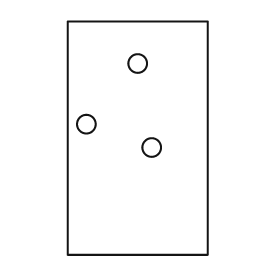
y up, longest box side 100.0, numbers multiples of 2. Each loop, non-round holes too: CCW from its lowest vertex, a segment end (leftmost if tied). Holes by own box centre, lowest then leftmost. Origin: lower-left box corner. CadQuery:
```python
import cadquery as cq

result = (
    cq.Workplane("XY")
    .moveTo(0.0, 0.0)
    .lineTo(60.0, 0.0)
    .lineTo(60.0, 100.0)
    .lineTo(0.0, 100.0)
    .close()
    .moveTo(36.0, 46.0)
    .circle(4.0)
    .moveTo(8.0, 56.0)
    .circle(4.0)
    .moveTo(30.0, 82.0)
    .circle(4.0)
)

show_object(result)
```